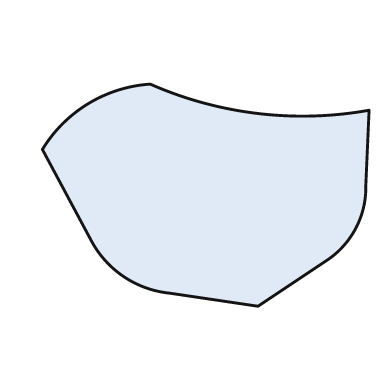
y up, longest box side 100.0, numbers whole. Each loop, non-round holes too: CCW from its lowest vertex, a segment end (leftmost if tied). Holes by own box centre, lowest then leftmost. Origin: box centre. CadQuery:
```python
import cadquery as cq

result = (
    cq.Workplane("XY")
    .moveTo(16.0, -34.0)
    .lineTo(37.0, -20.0)
    .threePointArc((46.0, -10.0), (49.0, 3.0))
    .lineTo(50.0, 26.0)
    .threePointArc((16.0, 25.0), (-17.0, 34.0))
    .threePointArc((-36.0, 28.0), (-50.0, 14.0))
    .lineTo(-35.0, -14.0)
    .threePointArc((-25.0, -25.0), (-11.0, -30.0))
    .close()
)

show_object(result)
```